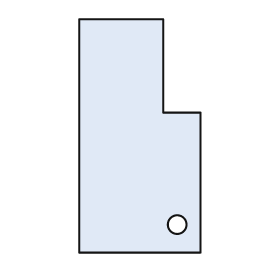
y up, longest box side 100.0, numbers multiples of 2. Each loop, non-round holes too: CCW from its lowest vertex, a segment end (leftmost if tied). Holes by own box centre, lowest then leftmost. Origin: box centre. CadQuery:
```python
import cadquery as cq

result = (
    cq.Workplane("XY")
    .moveTo(-26.0, -50.0)
    .lineTo(26.0, -50.0)
    .lineTo(26.0, 10.0)
    .lineTo(10.0, 10.0)
    .lineTo(10.0, 50.0)
    .lineTo(-26.0, 50.0)
    .close()
    .moveTo(16.0, -38.0)
    .circle(4.0)
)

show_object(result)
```